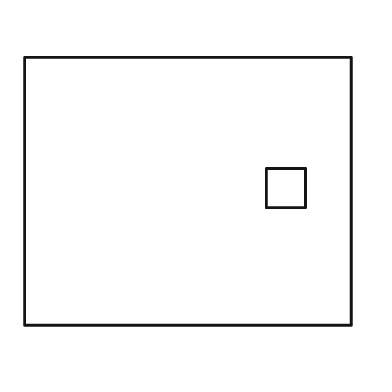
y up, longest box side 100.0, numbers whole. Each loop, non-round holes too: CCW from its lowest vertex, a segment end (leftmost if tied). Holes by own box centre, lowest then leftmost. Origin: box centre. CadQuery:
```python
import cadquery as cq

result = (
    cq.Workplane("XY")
    .moveTo(-50.0, -41.0)
    .lineTo(50.0, -41.0)
    .lineTo(50.0, 41.0)
    .lineTo(-50.0, 41.0)
    .close()
    .moveTo(24.0, -5.0)
    .lineTo(36.0, -5.0)
    .lineTo(36.0, 7.0)
    .lineTo(24.0, 7.0)
    .close()
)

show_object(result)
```